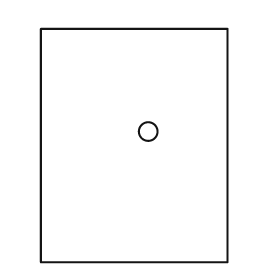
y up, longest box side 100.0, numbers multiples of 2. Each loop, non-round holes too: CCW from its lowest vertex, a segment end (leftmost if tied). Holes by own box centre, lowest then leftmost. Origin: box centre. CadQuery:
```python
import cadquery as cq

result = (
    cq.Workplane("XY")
    .moveTo(-40.0, -50.0)
    .lineTo(40.0, -50.0)
    .lineTo(40.0, 50.0)
    .lineTo(-40.0, 50.0)
    .close()
    .moveTo(6.0, 6.0)
    .circle(4.0)
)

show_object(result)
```